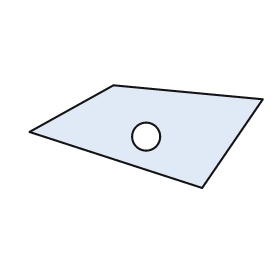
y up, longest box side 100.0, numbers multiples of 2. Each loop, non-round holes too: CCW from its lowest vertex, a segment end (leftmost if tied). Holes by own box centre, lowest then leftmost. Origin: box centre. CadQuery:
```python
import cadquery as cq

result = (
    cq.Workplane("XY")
    .moveTo(24.0, -22.0)
    .lineTo(50.0, 16.0)
    .lineTo(-14.0, 22.0)
    .lineTo(-50.0, 2.0)
    .close()
    .moveTo(0.0, 0.0)
    .circle(6.0)
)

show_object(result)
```